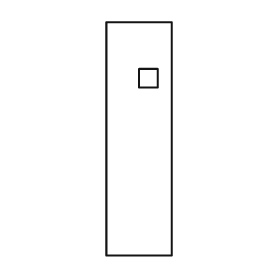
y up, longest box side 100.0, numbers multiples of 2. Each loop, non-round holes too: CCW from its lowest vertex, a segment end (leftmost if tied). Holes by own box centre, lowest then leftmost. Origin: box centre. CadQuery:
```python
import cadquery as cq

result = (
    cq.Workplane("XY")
    .moveTo(-14.0, -50.0)
    .lineTo(14.0, -50.0)
    .lineTo(14.0, 50.0)
    .lineTo(-14.0, 50.0)
    .close()
    .moveTo(0.0, 22.0)
    .lineTo(8.0, 22.0)
    .lineTo(8.0, 30.0)
    .lineTo(0.0, 30.0)
    .close()
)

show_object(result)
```